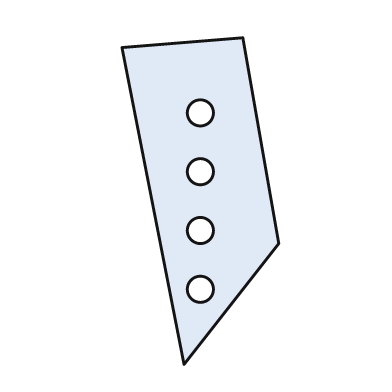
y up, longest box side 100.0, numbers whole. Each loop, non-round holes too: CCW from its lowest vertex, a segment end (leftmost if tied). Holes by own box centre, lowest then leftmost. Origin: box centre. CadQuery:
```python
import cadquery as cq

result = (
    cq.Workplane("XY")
    .moveTo(-5.0, -50.0)
    .lineTo(24.0, -13.0)
    .lineTo(13.0, 50.0)
    .lineTo(-24.0, 47.0)
    .close()
    .moveTo(0.0, -27.0)
    .circle(4.0)
    .moveTo(0.0, -9.0)
    .circle(4.0)
    .moveTo(0.0, 9.0)
    .circle(4.0)
    .moveTo(0.0, 27.0)
    .circle(4.0)
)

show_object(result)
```